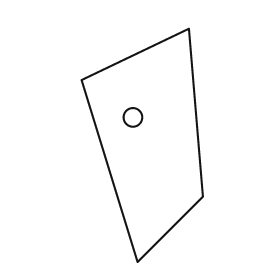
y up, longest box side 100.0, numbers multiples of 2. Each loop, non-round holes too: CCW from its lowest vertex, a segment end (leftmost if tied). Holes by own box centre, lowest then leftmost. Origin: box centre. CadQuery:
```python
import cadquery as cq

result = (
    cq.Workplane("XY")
    .moveTo(-2.0, -50.0)
    .lineTo(26.0, -22.0)
    .lineTo(20.0, 50.0)
    .lineTo(-26.0, 28.0)
    .close()
    .moveTo(-4.0, 12.0)
    .circle(4.0)
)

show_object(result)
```